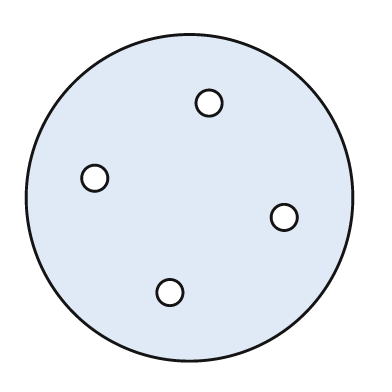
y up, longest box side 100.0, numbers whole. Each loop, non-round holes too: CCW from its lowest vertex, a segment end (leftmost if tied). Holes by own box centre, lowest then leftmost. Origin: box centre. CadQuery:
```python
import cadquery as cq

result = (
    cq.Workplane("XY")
    .moveTo(0.0, 0.0)
    .circle(50.0)
    .moveTo(-6.0, -29.0)
    .circle(4.0)
    .moveTo(29.0, -6.0)
    .circle(4.0)
    .moveTo(-29.0, 6.0)
    .circle(4.0)
    .moveTo(6.0, 29.0)
    .circle(4.0)
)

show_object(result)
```